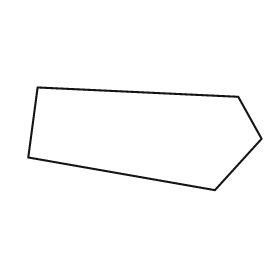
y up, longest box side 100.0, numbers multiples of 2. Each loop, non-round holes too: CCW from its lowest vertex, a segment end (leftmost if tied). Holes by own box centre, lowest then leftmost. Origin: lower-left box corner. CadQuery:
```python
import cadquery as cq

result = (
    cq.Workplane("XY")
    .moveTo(80.0, 0.0)
    .lineTo(100.0, 22.0)
    .lineTo(90.0, 40.0)
    .lineTo(4.0, 44.0)
    .lineTo(0.0, 14.0)
    .close()
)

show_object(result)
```